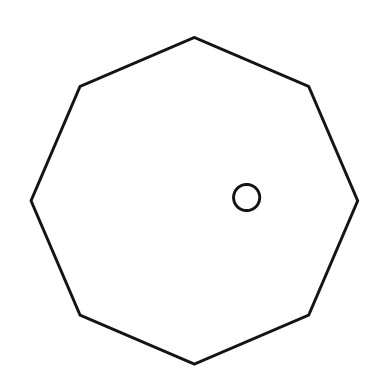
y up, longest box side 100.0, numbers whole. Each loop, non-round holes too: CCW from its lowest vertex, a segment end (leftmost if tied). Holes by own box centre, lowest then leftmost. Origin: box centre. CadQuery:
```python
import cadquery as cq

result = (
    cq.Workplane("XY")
    .moveTo(0.0, -50.0)
    .lineTo(35.0, -35.0)
    .lineTo(50.0, 0.0)
    .lineTo(35.0, 35.0)
    .lineTo(0.0, 50.0)
    .lineTo(-35.0, 35.0)
    .lineTo(-50.0, 0.0)
    .lineTo(-35.0, -35.0)
    .close()
    .moveTo(16.0, 1.0)
    .circle(4.0)
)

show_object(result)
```